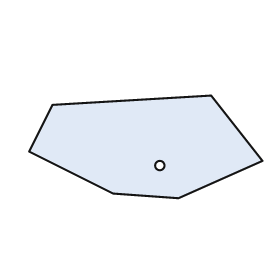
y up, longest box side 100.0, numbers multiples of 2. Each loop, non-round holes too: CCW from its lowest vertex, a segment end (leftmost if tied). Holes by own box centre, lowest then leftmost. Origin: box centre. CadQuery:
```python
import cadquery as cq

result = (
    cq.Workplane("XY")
    .moveTo(14.0, -22.0)
    .lineTo(50.0, -6.0)
    .lineTo(28.0, 22.0)
    .lineTo(-40.0, 18.0)
    .lineTo(-50.0, -2.0)
    .lineTo(-14.0, -20.0)
    .close()
    .moveTo(6.0, -8.0)
    .circle(2.0)
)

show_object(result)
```